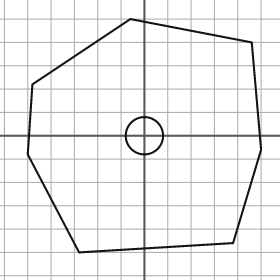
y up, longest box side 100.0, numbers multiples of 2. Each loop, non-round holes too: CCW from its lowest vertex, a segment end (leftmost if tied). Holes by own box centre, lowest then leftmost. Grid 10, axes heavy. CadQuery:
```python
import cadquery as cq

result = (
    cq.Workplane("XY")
    .moveTo(-28.0, -50.0)
    .lineTo(38.0, -46.0)
    .lineTo(50.0, -6.0)
    .lineTo(46.0, 40.0)
    .lineTo(-6.0, 50.0)
    .lineTo(-48.0, 22.0)
    .lineTo(-50.0, -8.0)
    .close()
    .moveTo(0.0, 0.0)
    .circle(8.0)
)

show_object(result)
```